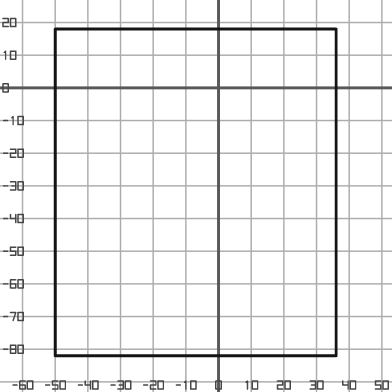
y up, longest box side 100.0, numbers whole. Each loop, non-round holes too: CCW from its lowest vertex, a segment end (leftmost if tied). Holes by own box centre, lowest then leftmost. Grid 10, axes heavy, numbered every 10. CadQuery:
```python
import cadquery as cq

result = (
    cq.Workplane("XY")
    .moveTo(-50.0, -82.0)
    .lineTo(36.0, -82.0)
    .lineTo(36.0, 18.0)
    .lineTo(-50.0, 18.0)
    .close()
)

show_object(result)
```